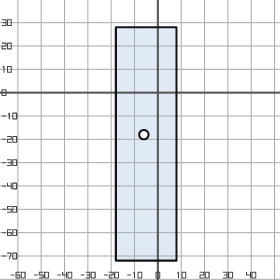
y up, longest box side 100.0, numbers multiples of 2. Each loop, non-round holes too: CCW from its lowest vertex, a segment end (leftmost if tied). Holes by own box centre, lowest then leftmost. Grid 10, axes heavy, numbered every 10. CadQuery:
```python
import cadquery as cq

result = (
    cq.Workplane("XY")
    .moveTo(-18.0, -72.0)
    .lineTo(8.0, -72.0)
    .lineTo(8.0, 28.0)
    .lineTo(-18.0, 28.0)
    .close()
    .moveTo(-6.0, -18.0)
    .circle(2.0)
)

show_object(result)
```